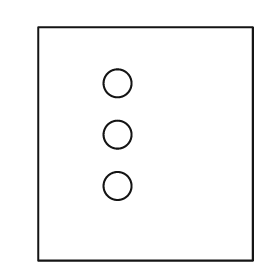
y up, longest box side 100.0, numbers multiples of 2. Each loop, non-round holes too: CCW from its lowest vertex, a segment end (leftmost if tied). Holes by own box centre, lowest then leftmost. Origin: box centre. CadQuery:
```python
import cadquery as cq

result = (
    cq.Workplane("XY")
    .moveTo(-46.0, -50.0)
    .lineTo(46.0, -50.0)
    .lineTo(46.0, 50.0)
    .lineTo(-46.0, 50.0)
    .close()
    .moveTo(-12.0, -18.0)
    .circle(6.0)
    .moveTo(-12.0, 4.0)
    .circle(6.0)
    .moveTo(-12.0, 26.0)
    .circle(6.0)
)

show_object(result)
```